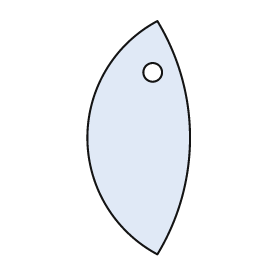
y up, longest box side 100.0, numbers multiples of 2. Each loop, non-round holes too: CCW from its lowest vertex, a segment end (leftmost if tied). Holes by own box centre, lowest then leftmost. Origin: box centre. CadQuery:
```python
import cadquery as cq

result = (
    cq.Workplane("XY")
    .moveTo(8.0, -50.0)
    .threePointArc((22.0, 0.0), (8.0, 50.0))
    .threePointArc((-22.0, 0.0), (8.0, -50.0))
    .close()
    .moveTo(6.0, 28.0)
    .circle(4.0)
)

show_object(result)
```